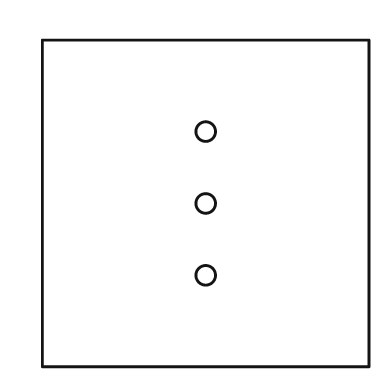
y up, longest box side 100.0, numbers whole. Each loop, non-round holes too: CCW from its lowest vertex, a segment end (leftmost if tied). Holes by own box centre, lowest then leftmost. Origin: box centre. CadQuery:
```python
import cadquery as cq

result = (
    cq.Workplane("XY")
    .moveTo(-50.0, -50.0)
    .lineTo(50.0, -50.0)
    .lineTo(50.0, 50.0)
    .lineTo(-50.0, 50.0)
    .close()
    .moveTo(0.0, -22.0)
    .circle(3.0)
    .moveTo(0.0, 0.0)
    .circle(3.0)
    .moveTo(0.0, 22.0)
    .circle(3.0)
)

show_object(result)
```